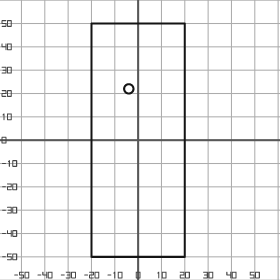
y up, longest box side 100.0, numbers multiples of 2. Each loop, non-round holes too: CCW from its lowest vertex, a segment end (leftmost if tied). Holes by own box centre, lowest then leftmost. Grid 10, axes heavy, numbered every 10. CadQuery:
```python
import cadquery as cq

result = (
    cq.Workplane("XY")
    .moveTo(-20.0, -50.0)
    .lineTo(20.0, -50.0)
    .lineTo(20.0, 50.0)
    .lineTo(-20.0, 50.0)
    .close()
    .moveTo(-4.0, 22.0)
    .circle(2.0)
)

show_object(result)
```